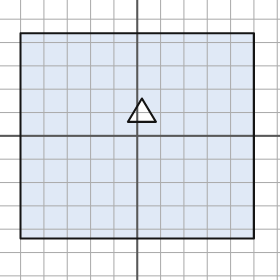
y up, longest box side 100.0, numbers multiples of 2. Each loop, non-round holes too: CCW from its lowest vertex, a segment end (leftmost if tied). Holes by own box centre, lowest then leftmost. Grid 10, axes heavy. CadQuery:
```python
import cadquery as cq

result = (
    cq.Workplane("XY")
    .moveTo(-50.0, -44.0)
    .lineTo(50.0, -44.0)
    .lineTo(50.0, 44.0)
    .lineTo(-50.0, 44.0)
    .close()
    .moveTo(-4.0, 6.0)
    .lineTo(8.0, 6.0)
    .lineTo(2.0, 16.0)
    .close()
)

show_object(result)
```